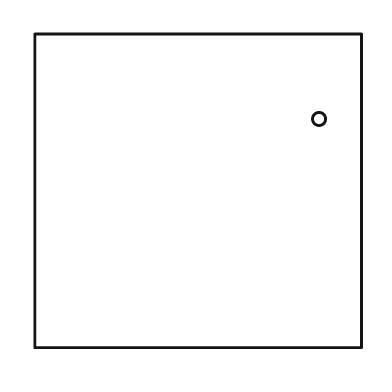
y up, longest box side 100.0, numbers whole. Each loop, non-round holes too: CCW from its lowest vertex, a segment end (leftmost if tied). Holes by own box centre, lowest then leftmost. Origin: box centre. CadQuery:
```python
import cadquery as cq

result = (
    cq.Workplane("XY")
    .moveTo(-50.0, -48.0)
    .lineTo(50.0, -48.0)
    .lineTo(50.0, 48.0)
    .lineTo(-50.0, 48.0)
    .close()
    .moveTo(37.0, 22.0)
    .circle(2.0)
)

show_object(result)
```